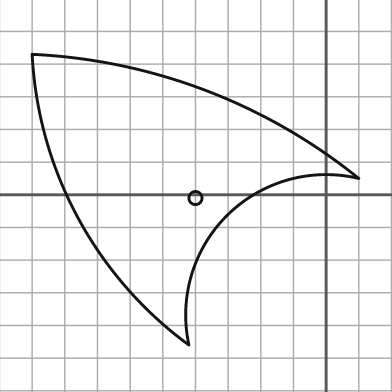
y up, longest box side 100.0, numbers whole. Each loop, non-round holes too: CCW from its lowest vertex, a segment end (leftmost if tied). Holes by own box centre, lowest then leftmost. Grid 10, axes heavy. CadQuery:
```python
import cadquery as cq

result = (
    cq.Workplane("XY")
    .moveTo(-42.0, -46.0)
    .threePointArc((-30.0, -6.0), (10.0, 5.0))
    .threePointArc((-37.0, 32.0), (-90.0, 43.0))
    .threePointArc((-76.0, -7.0), (-42.0, -46.0))
    .close()
    .moveTo(-40.0, -1.0)
    .circle(2.0)
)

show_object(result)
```